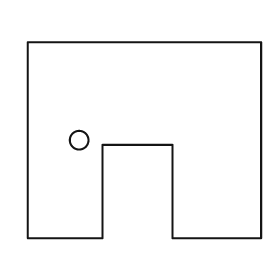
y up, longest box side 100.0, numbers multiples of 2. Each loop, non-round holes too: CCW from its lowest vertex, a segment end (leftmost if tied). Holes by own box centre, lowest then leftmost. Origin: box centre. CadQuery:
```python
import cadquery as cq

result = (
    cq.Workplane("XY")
    .moveTo(-50.0, -42.0)
    .lineTo(-18.0, -42.0)
    .lineTo(-18.0, -2.0)
    .lineTo(12.0, -2.0)
    .lineTo(12.0, -42.0)
    .lineTo(50.0, -42.0)
    .lineTo(50.0, 42.0)
    .lineTo(-50.0, 42.0)
    .close()
    .moveTo(-28.0, 0.0)
    .circle(4.0)
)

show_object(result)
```